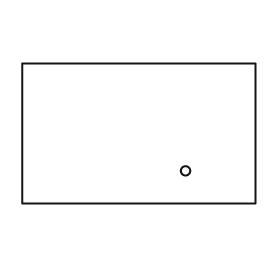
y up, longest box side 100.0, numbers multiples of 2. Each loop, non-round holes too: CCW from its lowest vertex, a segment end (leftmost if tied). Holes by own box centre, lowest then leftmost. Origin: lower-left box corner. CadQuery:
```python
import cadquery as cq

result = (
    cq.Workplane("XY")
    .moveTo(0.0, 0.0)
    .lineTo(100.0, 0.0)
    .lineTo(100.0, 60.0)
    .lineTo(0.0, 60.0)
    .close()
    .moveTo(70.0, 14.0)
    .circle(2.0)
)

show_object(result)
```